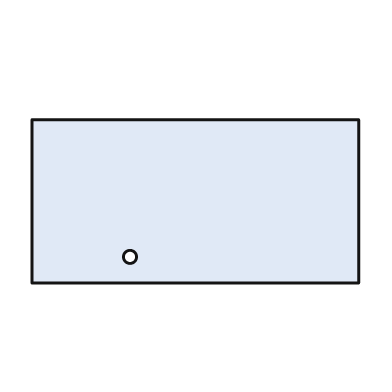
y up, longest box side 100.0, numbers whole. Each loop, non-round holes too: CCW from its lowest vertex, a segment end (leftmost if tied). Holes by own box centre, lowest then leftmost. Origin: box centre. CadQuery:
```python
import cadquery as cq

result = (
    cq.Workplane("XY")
    .moveTo(-50.0, -25.0)
    .lineTo(50.0, -25.0)
    .lineTo(50.0, 25.0)
    .lineTo(-50.0, 25.0)
    .close()
    .moveTo(-20.0, -17.0)
    .circle(2.0)
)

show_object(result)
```